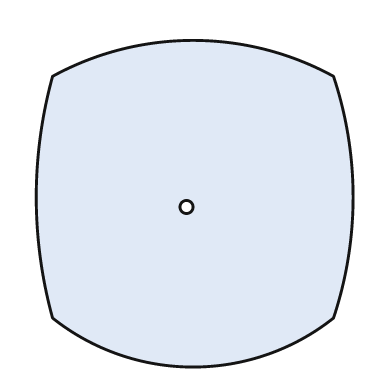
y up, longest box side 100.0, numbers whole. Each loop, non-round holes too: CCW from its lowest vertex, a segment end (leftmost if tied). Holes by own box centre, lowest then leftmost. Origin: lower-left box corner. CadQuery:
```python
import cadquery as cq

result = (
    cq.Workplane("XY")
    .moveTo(5.0, 15.0)
    .threePointArc((48.0, 0.0), (91.0, 15.0))
    .threePointArc((97.0, 52.0), (91.0, 89.0))
    .threePointArc((48.0, 100.0), (5.0, 89.0))
    .threePointArc((0.0, 52.0), (5.0, 15.0))
    .close()
    .moveTo(46.0, 49.0)
    .circle(2.0)
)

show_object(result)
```